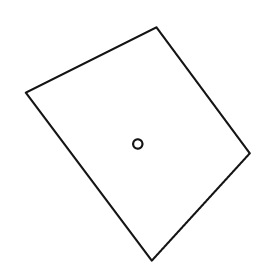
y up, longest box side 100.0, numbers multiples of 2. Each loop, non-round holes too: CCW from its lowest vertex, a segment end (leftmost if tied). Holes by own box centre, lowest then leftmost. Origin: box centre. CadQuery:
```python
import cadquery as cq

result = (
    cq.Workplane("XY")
    .moveTo(6.0, -50.0)
    .lineTo(48.0, -4.0)
    .lineTo(8.0, 50.0)
    .lineTo(-48.0, 22.0)
    .close()
    .moveTo(0.0, 0.0)
    .circle(2.0)
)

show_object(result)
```